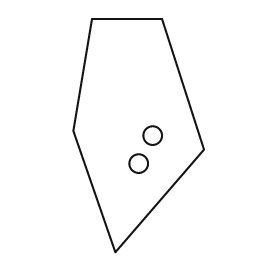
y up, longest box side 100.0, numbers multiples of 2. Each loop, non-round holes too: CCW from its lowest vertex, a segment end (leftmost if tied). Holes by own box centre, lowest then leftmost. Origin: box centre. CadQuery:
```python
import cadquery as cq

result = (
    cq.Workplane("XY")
    .moveTo(-10.0, -50.0)
    .lineTo(28.0, -6.0)
    .lineTo(10.0, 50.0)
    .lineTo(-20.0, 50.0)
    .lineTo(-28.0, 2.0)
    .close()
    .moveTo(0.0, -12.0)
    .circle(4.0)
    .moveTo(6.0, 0.0)
    .circle(4.0)
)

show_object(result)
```